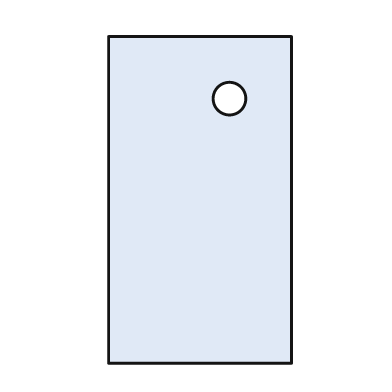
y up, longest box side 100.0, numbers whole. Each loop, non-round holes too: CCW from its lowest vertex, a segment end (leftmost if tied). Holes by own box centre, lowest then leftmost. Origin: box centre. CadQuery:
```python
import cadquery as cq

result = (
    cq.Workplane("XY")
    .moveTo(-28.0, -50.0)
    .lineTo(28.0, -50.0)
    .lineTo(28.0, 50.0)
    .lineTo(-28.0, 50.0)
    .close()
    .moveTo(9.0, 31.0)
    .circle(5.0)
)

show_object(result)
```